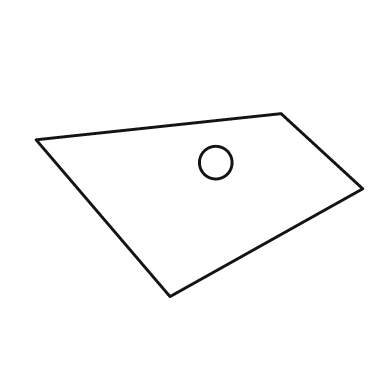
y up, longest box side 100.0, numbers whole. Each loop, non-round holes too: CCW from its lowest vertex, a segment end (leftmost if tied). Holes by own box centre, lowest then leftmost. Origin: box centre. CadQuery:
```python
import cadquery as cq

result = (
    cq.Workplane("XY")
    .moveTo(-9.0, -28.0)
    .lineTo(50.0, 5.0)
    .lineTo(25.0, 28.0)
    .lineTo(-50.0, 20.0)
    .close()
    .moveTo(5.0, 13.0)
    .circle(5.0)
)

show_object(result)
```